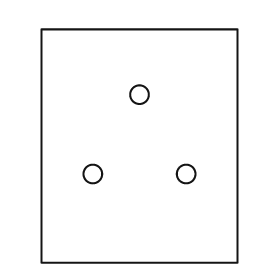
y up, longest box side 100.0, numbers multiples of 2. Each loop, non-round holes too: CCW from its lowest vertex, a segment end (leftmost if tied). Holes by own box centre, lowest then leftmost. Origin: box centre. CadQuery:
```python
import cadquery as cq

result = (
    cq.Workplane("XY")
    .moveTo(-42.0, -50.0)
    .lineTo(42.0, -50.0)
    .lineTo(42.0, 50.0)
    .lineTo(-42.0, 50.0)
    .close()
    .moveTo(-20.0, -12.0)
    .circle(4.0)
    .moveTo(20.0, -12.0)
    .circle(4.0)
    .moveTo(0.0, 22.0)
    .circle(4.0)
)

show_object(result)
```